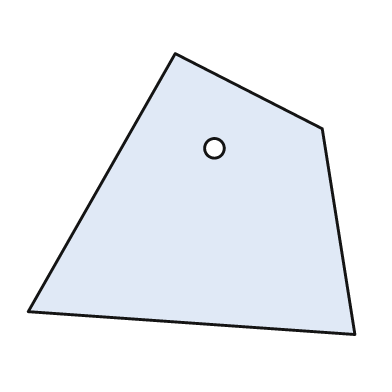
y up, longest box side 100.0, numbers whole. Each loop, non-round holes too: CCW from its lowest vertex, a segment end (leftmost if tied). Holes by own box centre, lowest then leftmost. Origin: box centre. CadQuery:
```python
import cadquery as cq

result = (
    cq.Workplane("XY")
    .moveTo(50.0, -43.0)
    .lineTo(40.0, 20.0)
    .lineTo(-5.0, 43.0)
    .lineTo(-50.0, -36.0)
    .close()
    .moveTo(7.0, 14.0)
    .circle(3.0)
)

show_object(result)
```